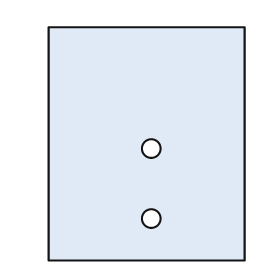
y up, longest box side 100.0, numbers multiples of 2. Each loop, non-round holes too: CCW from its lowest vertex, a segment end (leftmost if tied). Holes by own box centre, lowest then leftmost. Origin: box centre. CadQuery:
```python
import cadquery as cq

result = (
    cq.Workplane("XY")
    .moveTo(-42.0, -50.0)
    .lineTo(42.0, -50.0)
    .lineTo(42.0, 50.0)
    .lineTo(-42.0, 50.0)
    .close()
    .moveTo(2.0, -32.0)
    .circle(4.0)
    .moveTo(2.0, -2.0)
    .circle(4.0)
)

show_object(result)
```